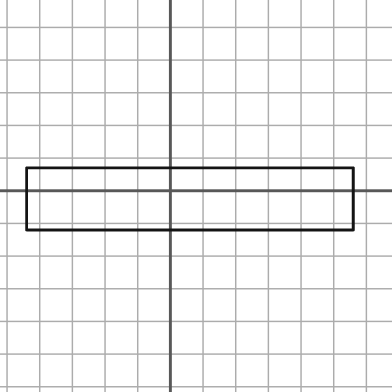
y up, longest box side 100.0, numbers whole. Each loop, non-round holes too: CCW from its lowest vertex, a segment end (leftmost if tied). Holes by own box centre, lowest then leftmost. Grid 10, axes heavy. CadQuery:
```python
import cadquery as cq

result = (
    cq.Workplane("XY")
    .moveTo(-44.0, -12.0)
    .lineTo(56.0, -12.0)
    .lineTo(56.0, 7.0)
    .lineTo(-44.0, 7.0)
    .close()
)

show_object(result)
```